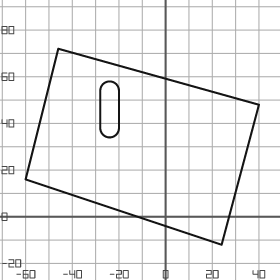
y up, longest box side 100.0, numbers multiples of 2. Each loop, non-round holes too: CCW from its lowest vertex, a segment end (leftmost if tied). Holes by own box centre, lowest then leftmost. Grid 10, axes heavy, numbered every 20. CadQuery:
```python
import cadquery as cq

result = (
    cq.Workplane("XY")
    .moveTo(24.0, -12.0)
    .lineTo(40.0, 48.0)
    .lineTo(-46.0, 72.0)
    .lineTo(-60.0, 16.0)
    .close()
    .moveTo(-28.0, 38.0)
    .threePointArc((-24.0, 34.0), (-20.0, 38.0))
    .lineTo(-20.0, 54.0)
    .threePointArc((-24.0, 58.0), (-28.0, 54.0))
    .close()
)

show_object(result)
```